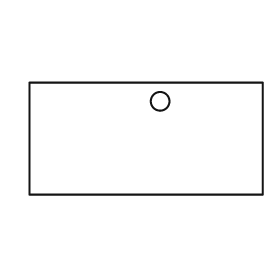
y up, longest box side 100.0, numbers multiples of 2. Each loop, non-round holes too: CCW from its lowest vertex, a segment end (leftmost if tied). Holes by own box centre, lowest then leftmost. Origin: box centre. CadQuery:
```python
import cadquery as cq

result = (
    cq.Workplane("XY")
    .moveTo(-50.0, -24.0)
    .lineTo(50.0, -24.0)
    .lineTo(50.0, 24.0)
    .lineTo(-50.0, 24.0)
    .close()
    .moveTo(6.0, 16.0)
    .circle(4.0)
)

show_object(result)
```